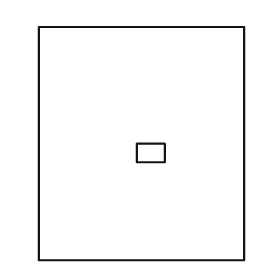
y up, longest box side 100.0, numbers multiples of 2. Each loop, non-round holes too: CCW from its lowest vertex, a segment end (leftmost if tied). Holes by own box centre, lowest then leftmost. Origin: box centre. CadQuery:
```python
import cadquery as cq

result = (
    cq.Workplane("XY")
    .moveTo(-44.0, -50.0)
    .lineTo(44.0, -50.0)
    .lineTo(44.0, 50.0)
    .lineTo(-44.0, 50.0)
    .close()
    .moveTo(-2.0, -8.0)
    .lineTo(10.0, -8.0)
    .lineTo(10.0, 0.0)
    .lineTo(-2.0, 0.0)
    .close()
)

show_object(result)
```